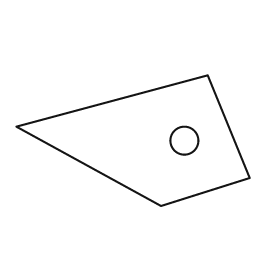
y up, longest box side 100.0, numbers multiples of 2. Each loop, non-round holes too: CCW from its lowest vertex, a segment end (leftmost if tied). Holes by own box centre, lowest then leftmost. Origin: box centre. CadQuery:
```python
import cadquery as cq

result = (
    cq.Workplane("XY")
    .moveTo(12.0, -28.0)
    .lineTo(50.0, -16.0)
    .lineTo(32.0, 28.0)
    .lineTo(-50.0, 6.0)
    .close()
    .moveTo(22.0, 0.0)
    .circle(6.0)
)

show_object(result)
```